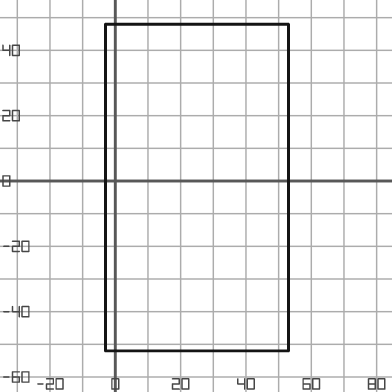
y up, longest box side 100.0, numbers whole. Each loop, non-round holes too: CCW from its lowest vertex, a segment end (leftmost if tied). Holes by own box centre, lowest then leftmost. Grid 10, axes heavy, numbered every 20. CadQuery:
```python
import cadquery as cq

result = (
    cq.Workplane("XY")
    .moveTo(-3.0, -52.0)
    .lineTo(53.0, -52.0)
    .lineTo(53.0, 48.0)
    .lineTo(-3.0, 48.0)
    .close()
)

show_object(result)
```